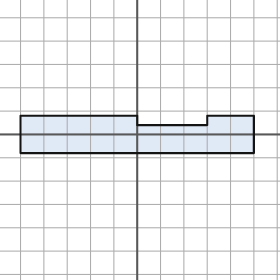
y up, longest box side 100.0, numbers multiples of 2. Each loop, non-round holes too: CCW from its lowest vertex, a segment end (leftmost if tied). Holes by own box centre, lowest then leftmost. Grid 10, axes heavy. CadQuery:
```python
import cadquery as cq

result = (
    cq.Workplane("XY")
    .moveTo(-50.0, -8.0)
    .lineTo(50.0, -8.0)
    .lineTo(50.0, 8.0)
    .lineTo(30.0, 8.0)
    .lineTo(30.0, 4.0)
    .lineTo(0.0, 4.0)
    .lineTo(0.0, 8.0)
    .lineTo(-50.0, 8.0)
    .close()
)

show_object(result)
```